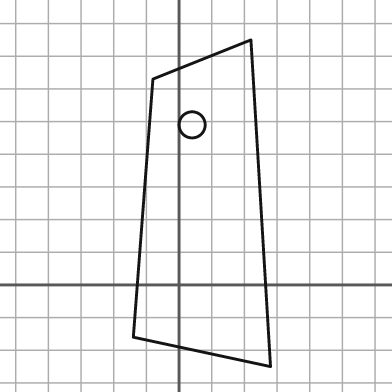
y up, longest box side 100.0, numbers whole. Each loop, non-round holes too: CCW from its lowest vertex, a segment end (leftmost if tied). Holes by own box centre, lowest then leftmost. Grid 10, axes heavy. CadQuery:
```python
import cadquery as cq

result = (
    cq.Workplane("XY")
    .moveTo(28.0, -25.0)
    .lineTo(22.0, 75.0)
    .lineTo(-8.0, 63.0)
    .lineTo(-14.0, -16.0)
    .close()
    .moveTo(4.0, 49.0)
    .circle(4.0)
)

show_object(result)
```